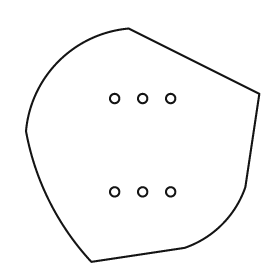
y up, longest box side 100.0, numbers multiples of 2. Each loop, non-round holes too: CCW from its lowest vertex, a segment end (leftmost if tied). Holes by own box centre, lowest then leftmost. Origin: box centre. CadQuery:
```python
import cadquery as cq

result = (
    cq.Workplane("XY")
    .moveTo(-22.0, -50.0)
    .lineTo(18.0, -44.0)
    .threePointArc((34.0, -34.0), (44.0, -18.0))
    .lineTo(50.0, 22.0)
    .lineTo(-6.0, 50.0)
    .threePointArc((-36.0, 36.0), (-50.0, 6.0))
    .threePointArc((-40.0, -24.0), (-22.0, -50.0))
    .close()
    .moveTo(-12.0, -20.0)
    .circle(2.0)
    .moveTo(0.0, -20.0)
    .circle(2.0)
    .moveTo(12.0, -20.0)
    .circle(2.0)
    .moveTo(-12.0, 20.0)
    .circle(2.0)
    .moveTo(0.0, 20.0)
    .circle(2.0)
    .moveTo(12.0, 20.0)
    .circle(2.0)
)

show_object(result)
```